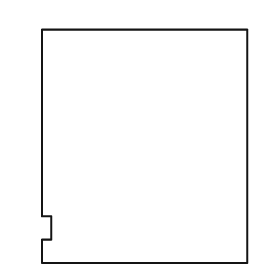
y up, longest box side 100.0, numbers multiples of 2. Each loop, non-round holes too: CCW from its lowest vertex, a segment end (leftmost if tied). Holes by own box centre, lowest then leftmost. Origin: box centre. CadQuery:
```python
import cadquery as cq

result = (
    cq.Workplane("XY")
    .moveTo(-44.0, -50.0)
    .lineTo(44.0, -50.0)
    .lineTo(44.0, 50.0)
    .lineTo(-44.0, 50.0)
    .lineTo(-44.0, -30.0)
    .lineTo(-40.0, -30.0)
    .lineTo(-40.0, -40.0)
    .lineTo(-44.0, -40.0)
    .close()
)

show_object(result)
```